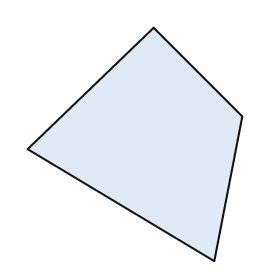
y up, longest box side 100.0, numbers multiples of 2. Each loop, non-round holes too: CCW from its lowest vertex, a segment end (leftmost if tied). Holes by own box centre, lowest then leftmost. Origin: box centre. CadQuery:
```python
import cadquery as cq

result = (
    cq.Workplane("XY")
    .moveTo(34.0, -50.0)
    .lineTo(46.0, 12.0)
    .lineTo(8.0, 50.0)
    .lineTo(-46.0, -2.0)
    .close()
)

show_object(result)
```